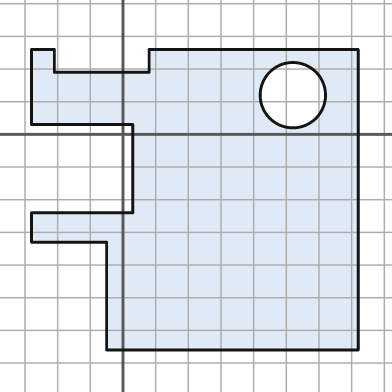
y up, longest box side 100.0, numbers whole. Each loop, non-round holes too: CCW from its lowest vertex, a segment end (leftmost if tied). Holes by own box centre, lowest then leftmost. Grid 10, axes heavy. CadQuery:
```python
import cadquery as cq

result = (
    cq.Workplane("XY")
    .moveTo(-5.0, -66.0)
    .lineTo(72.0, -66.0)
    .lineTo(72.0, 26.0)
    .lineTo(8.0, 26.0)
    .lineTo(8.0, 19.0)
    .lineTo(-21.0, 19.0)
    .lineTo(-21.0, 26.0)
    .lineTo(-28.0, 26.0)
    .lineTo(-28.0, 3.0)
    .lineTo(3.0, 3.0)
    .lineTo(3.0, -24.0)
    .lineTo(-28.0, -24.0)
    .lineTo(-28.0, -33.0)
    .lineTo(-5.0, -33.0)
    .close()
    .moveTo(52.0, 12.0)
    .circle(10.0)
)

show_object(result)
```